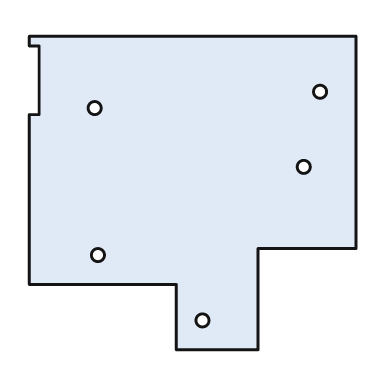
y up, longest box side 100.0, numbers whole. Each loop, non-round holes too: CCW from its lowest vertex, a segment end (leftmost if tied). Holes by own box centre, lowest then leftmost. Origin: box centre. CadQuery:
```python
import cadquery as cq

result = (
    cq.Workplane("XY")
    .moveTo(-5.0, -48.0)
    .lineTo(20.0, -48.0)
    .lineTo(20.0, -17.0)
    .lineTo(50.0, -17.0)
    .lineTo(50.0, 48.0)
    .lineTo(-50.0, 48.0)
    .lineTo(-50.0, 45.0)
    .lineTo(-47.0, 45.0)
    .lineTo(-47.0, 24.0)
    .lineTo(-50.0, 24.0)
    .lineTo(-50.0, -28.0)
    .lineTo(-5.0, -28.0)
    .close()
    .moveTo(3.0, -39.0)
    .circle(2.0)
    .moveTo(-29.0, -19.0)
    .circle(2.0)
    .moveTo(34.0, 8.0)
    .circle(2.0)
    .moveTo(-30.0, 26.0)
    .circle(2.0)
    .moveTo(39.0, 31.0)
    .circle(2.0)
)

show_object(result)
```